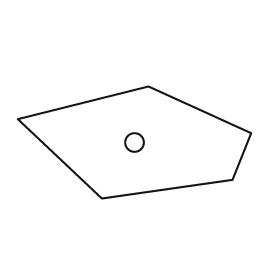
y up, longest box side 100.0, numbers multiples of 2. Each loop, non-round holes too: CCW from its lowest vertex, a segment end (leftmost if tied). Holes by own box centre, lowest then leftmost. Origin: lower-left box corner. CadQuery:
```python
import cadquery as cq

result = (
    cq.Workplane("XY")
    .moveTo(36.0, 0.0)
    .lineTo(92.0, 8.0)
    .lineTo(100.0, 28.0)
    .lineTo(56.0, 48.0)
    .lineTo(0.0, 34.0)
    .close()
    .moveTo(50.0, 24.0)
    .circle(4.0)
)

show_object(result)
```